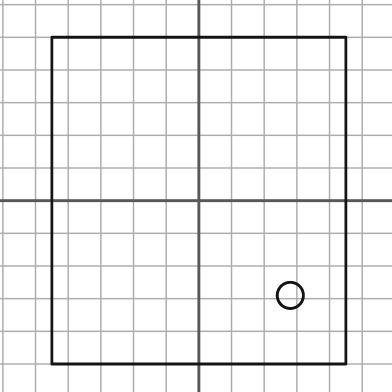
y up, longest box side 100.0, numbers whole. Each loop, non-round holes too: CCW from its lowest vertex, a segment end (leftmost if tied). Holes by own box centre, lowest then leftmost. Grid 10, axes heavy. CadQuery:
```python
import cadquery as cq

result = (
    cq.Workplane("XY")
    .moveTo(-45.0, -50.0)
    .lineTo(45.0, -50.0)
    .lineTo(45.0, 50.0)
    .lineTo(-45.0, 50.0)
    .close()
    .moveTo(28.0, -29.0)
    .circle(4.0)
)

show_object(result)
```